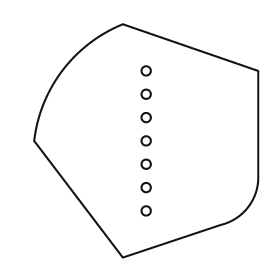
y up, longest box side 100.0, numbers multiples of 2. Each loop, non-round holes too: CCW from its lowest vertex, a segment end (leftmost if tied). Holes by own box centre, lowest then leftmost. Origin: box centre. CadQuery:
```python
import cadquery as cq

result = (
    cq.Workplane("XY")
    .moveTo(-10.0, -50.0)
    .lineTo(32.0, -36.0)
    .threePointArc((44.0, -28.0), (48.0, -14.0))
    .lineTo(48.0, 30.0)
    .lineTo(-10.0, 50.0)
    .threePointArc((-36.0, 30.0), (-48.0, 0.0))
    .close()
    .moveTo(0.0, -30.0)
    .circle(2.0)
    .moveTo(0.0, -20.0)
    .circle(2.0)
    .moveTo(0.0, -10.0)
    .circle(2.0)
    .moveTo(0.0, 0.0)
    .circle(2.0)
    .moveTo(0.0, 10.0)
    .circle(2.0)
    .moveTo(0.0, 20.0)
    .circle(2.0)
    .moveTo(0.0, 30.0)
    .circle(2.0)
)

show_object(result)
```